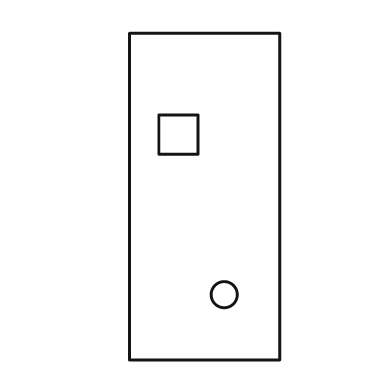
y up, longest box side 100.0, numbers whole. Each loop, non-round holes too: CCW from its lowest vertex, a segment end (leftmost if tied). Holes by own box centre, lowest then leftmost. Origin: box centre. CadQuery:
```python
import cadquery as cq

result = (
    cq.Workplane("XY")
    .moveTo(-23.0, -50.0)
    .lineTo(23.0, -50.0)
    .lineTo(23.0, 50.0)
    .lineTo(-23.0, 50.0)
    .close()
    .moveTo(6.0, -30.0)
    .circle(4.0)
    .moveTo(-14.0, 13.0)
    .lineTo(-2.0, 13.0)
    .lineTo(-2.0, 25.0)
    .lineTo(-14.0, 25.0)
    .close()
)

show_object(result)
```